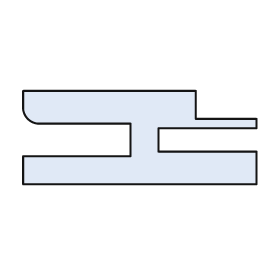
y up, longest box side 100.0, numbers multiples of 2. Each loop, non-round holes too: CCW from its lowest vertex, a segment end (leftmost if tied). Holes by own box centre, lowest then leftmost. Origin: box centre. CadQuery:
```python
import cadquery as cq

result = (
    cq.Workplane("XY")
    .moveTo(-50.0, -20.0)
    .lineTo(50.0, -20.0)
    .lineTo(50.0, -6.0)
    .lineTo(8.0, -6.0)
    .lineTo(8.0, 4.0)
    .lineTo(50.0, 4.0)
    .lineTo(50.0, 8.0)
    .lineTo(24.0, 8.0)
    .lineTo(24.0, 20.0)
    .lineTo(-50.0, 20.0)
    .lineTo(-50.0, 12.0)
    .threePointArc((-48.0, 8.0), (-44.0, 6.0))
    .lineTo(-4.0, 6.0)
    .lineTo(-4.0, -8.0)
    .lineTo(-50.0, -8.0)
    .close()
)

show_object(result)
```